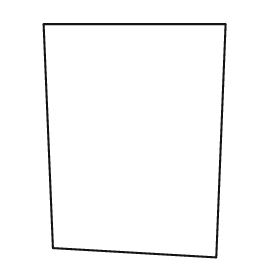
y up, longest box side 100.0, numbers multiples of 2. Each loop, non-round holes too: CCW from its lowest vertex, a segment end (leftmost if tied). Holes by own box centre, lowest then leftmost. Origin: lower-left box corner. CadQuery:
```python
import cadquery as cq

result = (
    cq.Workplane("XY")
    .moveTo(74.0, 0.0)
    .lineTo(78.0, 100.0)
    .lineTo(0.0, 100.0)
    .lineTo(4.0, 4.0)
    .close()
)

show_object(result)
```